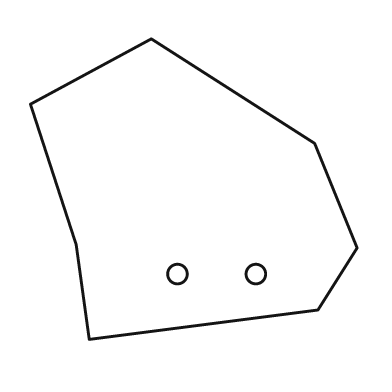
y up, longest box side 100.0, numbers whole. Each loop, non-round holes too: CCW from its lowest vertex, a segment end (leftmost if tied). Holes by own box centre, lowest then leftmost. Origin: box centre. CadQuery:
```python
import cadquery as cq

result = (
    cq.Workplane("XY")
    .moveTo(-32.0, -46.0)
    .lineTo(38.0, -37.0)
    .lineTo(50.0, -18.0)
    .lineTo(37.0, 14.0)
    .lineTo(-13.0, 46.0)
    .lineTo(-50.0, 26.0)
    .lineTo(-36.0, -17.0)
    .close()
    .moveTo(-5.0, -26.0)
    .circle(3.0)
    .moveTo(19.0, -26.0)
    .circle(3.0)
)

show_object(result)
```